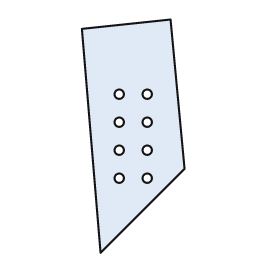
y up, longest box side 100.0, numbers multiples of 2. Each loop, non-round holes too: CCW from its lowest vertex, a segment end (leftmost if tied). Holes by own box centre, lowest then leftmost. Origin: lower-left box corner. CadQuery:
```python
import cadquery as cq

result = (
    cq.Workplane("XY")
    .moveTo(8.0, 0.0)
    .lineTo(44.0, 36.0)
    .lineTo(38.0, 100.0)
    .lineTo(0.0, 96.0)
    .close()
    .moveTo(16.0, 32.0)
    .circle(2.0)
    .moveTo(28.0, 32.0)
    .circle(2.0)
    .moveTo(16.0, 44.0)
    .circle(2.0)
    .moveTo(28.0, 44.0)
    .circle(2.0)
    .moveTo(16.0, 56.0)
    .circle(2.0)
    .moveTo(28.0, 56.0)
    .circle(2.0)
    .moveTo(16.0, 68.0)
    .circle(2.0)
    .moveTo(28.0, 68.0)
    .circle(2.0)
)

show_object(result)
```